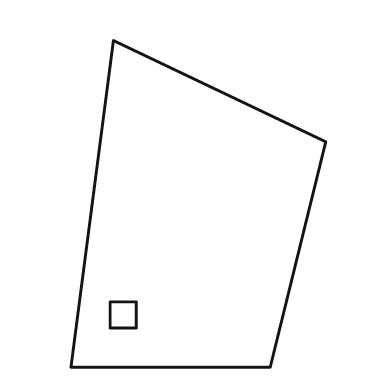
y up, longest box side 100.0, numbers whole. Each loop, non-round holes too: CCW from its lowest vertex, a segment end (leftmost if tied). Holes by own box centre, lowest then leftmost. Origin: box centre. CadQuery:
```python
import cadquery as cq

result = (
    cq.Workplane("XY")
    .moveTo(-39.0, -50.0)
    .lineTo(22.0, -50.0)
    .lineTo(39.0, 19.0)
    .lineTo(-26.0, 50.0)
    .close()
    .moveTo(-27.0, -38.0)
    .lineTo(-19.0, -38.0)
    .lineTo(-19.0, -30.0)
    .lineTo(-27.0, -30.0)
    .close()
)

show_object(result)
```